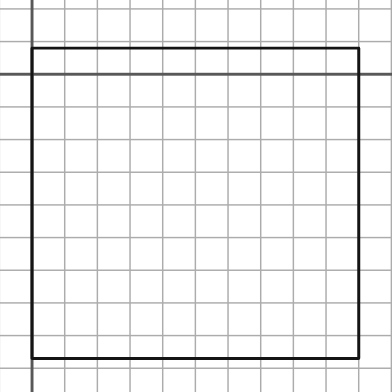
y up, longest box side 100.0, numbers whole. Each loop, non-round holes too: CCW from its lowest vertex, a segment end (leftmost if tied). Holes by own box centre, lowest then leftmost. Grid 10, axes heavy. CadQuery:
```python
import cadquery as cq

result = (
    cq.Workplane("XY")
    .moveTo(0.0, -87.0)
    .lineTo(100.0, -87.0)
    .lineTo(100.0, 8.0)
    .lineTo(0.0, 8.0)
    .close()
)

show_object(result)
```